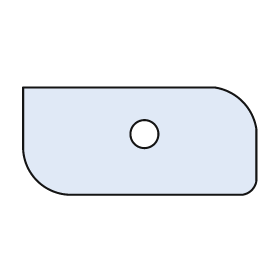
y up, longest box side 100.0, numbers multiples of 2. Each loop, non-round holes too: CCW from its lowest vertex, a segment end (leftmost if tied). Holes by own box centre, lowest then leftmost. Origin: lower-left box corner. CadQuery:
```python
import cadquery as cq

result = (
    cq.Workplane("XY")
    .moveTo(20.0, 0.0)
    .lineTo(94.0, 0.0)
    .threePointArc((98.0, 2.0), (100.0, 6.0))
    .lineTo(100.0, 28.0)
    .threePointArc((94.0, 40.0), (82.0, 46.0))
    .lineTo(0.0, 46.0)
    .lineTo(0.0, 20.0)
    .threePointArc((6.0, 6.0), (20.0, 0.0))
    .close()
    .moveTo(52.0, 26.0)
    .circle(6.0)
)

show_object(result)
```